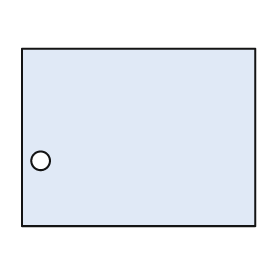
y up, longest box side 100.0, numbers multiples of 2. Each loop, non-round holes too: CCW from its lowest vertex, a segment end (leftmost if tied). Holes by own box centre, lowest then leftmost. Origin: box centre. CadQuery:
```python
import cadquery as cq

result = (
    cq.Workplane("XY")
    .moveTo(-50.0, -38.0)
    .lineTo(50.0, -38.0)
    .lineTo(50.0, 38.0)
    .lineTo(-50.0, 38.0)
    .close()
    .moveTo(-42.0, -10.0)
    .circle(4.0)
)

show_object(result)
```